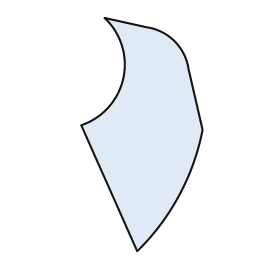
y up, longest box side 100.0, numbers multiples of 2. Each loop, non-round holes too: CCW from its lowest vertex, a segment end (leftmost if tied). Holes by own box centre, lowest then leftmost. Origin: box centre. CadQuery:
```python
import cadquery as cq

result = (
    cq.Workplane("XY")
    .moveTo(-2.0, -50.0)
    .threePointArc((16.0, -26.0), (26.0, 2.0))
    .lineTo(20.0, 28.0)
    .threePointArc((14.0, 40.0), (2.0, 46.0))
    .lineTo(-16.0, 50.0)
    .threePointArc((-8.0, 24.0), (-26.0, 4.0))
    .close()
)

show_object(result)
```